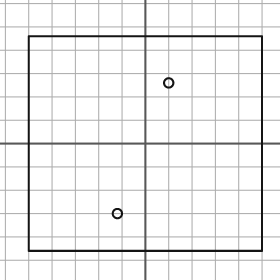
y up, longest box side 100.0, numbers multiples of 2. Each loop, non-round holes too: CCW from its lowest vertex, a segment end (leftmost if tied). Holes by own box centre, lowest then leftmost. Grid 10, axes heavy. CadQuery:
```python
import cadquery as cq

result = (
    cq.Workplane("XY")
    .moveTo(-50.0, -46.0)
    .lineTo(50.0, -46.0)
    .lineTo(50.0, 46.0)
    .lineTo(-50.0, 46.0)
    .close()
    .moveTo(-12.0, -30.0)
    .circle(2.0)
    .moveTo(10.0, 26.0)
    .circle(2.0)
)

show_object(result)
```